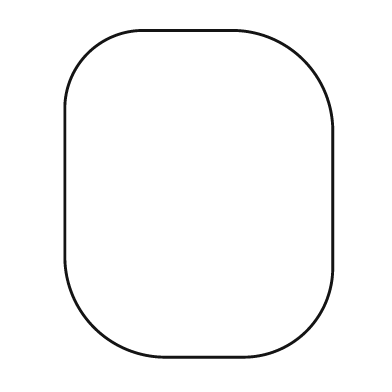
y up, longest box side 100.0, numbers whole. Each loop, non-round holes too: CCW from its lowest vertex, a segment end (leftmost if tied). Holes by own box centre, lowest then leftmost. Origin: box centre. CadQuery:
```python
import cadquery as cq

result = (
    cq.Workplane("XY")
    .moveTo(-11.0, -50.0)
    .lineTo(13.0, -50.0)
    .threePointArc((33.0, -42.0), (41.0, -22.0))
    .lineTo(41.0, 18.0)
    .threePointArc((32.0, 41.0), (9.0, 50.0))
    .lineTo(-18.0, 50.0)
    .threePointArc((-34.0, 43.0), (-41.0, 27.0))
    .lineTo(-41.0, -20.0)
    .threePointArc((-32.0, -41.0), (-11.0, -50.0))
    .close()
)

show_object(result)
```